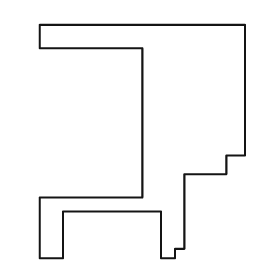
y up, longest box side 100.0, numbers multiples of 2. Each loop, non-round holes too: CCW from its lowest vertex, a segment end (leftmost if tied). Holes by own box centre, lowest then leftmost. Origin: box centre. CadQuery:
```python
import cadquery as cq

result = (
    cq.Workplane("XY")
    .moveTo(-44.0, -50.0)
    .lineTo(-34.0, -50.0)
    .lineTo(-34.0, -30.0)
    .lineTo(8.0, -30.0)
    .lineTo(8.0, -50.0)
    .lineTo(14.0, -50.0)
    .lineTo(14.0, -46.0)
    .lineTo(18.0, -46.0)
    .lineTo(18.0, -14.0)
    .lineTo(36.0, -14.0)
    .lineTo(36.0, -6.0)
    .lineTo(44.0, -6.0)
    .lineTo(44.0, 50.0)
    .lineTo(-44.0, 50.0)
    .lineTo(-44.0, 40.0)
    .lineTo(0.0, 40.0)
    .lineTo(0.0, -24.0)
    .lineTo(-44.0, -24.0)
    .close()
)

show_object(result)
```